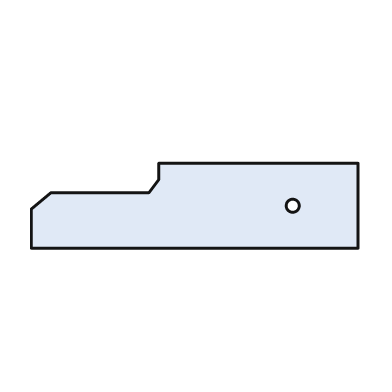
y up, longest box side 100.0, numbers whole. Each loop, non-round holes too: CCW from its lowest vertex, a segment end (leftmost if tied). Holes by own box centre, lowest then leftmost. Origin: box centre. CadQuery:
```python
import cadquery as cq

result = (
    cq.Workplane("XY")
    .moveTo(-50.0, -13.0)
    .lineTo(50.0, -13.0)
    .lineTo(50.0, 13.0)
    .lineTo(-11.0, 13.0)
    .lineTo(-11.0, 8.0)
    .lineTo(-14.0, 4.0)
    .lineTo(-44.0, 4.0)
    .lineTo(-50.0, -1.0)
    .close()
    .moveTo(30.0, 0.0)
    .circle(2.0)
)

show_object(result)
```